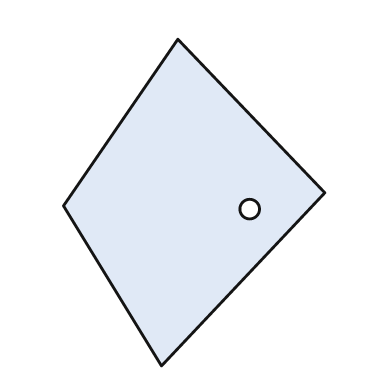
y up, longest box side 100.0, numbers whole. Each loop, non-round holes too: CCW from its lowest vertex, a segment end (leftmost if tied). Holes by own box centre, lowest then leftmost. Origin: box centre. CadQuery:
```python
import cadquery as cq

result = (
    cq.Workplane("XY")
    .moveTo(-10.0, -50.0)
    .lineTo(40.0, 3.0)
    .lineTo(-5.0, 50.0)
    .lineTo(-40.0, -1.0)
    .close()
    .moveTo(17.0, -2.0)
    .circle(3.0)
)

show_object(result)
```